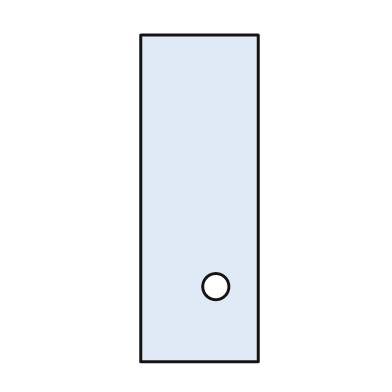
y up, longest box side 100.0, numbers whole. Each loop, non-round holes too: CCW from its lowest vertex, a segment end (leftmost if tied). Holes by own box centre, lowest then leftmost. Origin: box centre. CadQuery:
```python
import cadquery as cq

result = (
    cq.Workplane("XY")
    .moveTo(-18.0, -50.0)
    .lineTo(18.0, -50.0)
    .lineTo(18.0, 50.0)
    .lineTo(-18.0, 50.0)
    .close()
    .moveTo(5.0, -27.0)
    .circle(4.0)
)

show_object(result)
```